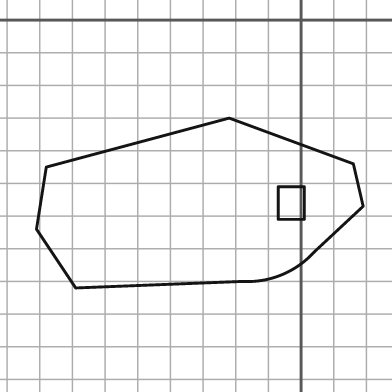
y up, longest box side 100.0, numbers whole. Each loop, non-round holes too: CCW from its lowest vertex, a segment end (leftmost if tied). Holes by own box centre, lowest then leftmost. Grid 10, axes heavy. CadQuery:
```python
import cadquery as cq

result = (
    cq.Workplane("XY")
    .moveTo(-69.0, -82.0)
    .lineTo(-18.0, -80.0)
    .threePointArc((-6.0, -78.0), (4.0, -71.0))
    .lineTo(19.0, -57.0)
    .lineTo(16.0, -44.0)
    .lineTo(-22.0, -30.0)
    .lineTo(-78.0, -45.0)
    .lineTo(-81.0, -64.0)
    .close()
    .moveTo(-7.0, -61.0)
    .lineTo(1.0, -61.0)
    .lineTo(1.0, -51.0)
    .lineTo(-7.0, -51.0)
    .close()
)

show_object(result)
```